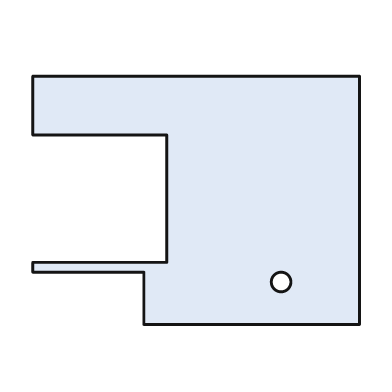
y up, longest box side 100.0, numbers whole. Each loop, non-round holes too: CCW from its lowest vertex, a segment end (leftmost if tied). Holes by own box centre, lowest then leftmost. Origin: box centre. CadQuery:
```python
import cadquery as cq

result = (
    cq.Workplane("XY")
    .moveTo(-16.0, -38.0)
    .lineTo(50.0, -38.0)
    .lineTo(50.0, 38.0)
    .lineTo(-50.0, 38.0)
    .lineTo(-50.0, 20.0)
    .lineTo(-9.0, 20.0)
    .lineTo(-9.0, -19.0)
    .lineTo(-50.0, -19.0)
    .lineTo(-50.0, -22.0)
    .lineTo(-16.0, -22.0)
    .close()
    .moveTo(26.0, -25.0)
    .circle(3.0)
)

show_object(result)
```